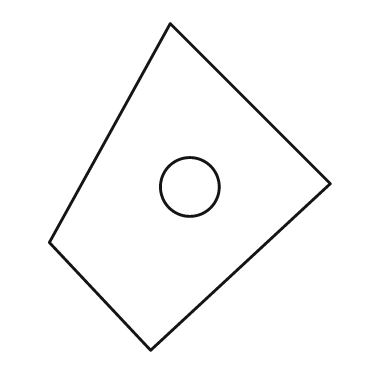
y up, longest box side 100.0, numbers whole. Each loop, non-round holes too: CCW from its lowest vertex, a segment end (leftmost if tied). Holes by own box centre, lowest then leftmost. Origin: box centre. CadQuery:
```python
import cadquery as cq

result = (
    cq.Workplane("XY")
    .moveTo(-12.0, -50.0)
    .lineTo(43.0, 1.0)
    .lineTo(-6.0, 50.0)
    .lineTo(-43.0, -17.0)
    .close()
    .moveTo(0.0, 0.0)
    .circle(9.0)
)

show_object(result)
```